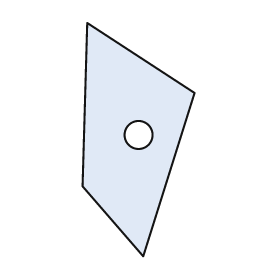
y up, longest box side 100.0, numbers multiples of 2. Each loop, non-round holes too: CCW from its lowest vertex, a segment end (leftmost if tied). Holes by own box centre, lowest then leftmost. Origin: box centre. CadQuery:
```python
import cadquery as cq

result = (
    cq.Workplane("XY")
    .moveTo(2.0, -50.0)
    .lineTo(24.0, 20.0)
    .lineTo(-22.0, 50.0)
    .lineTo(-24.0, -20.0)
    .close()
    .moveTo(0.0, 2.0)
    .circle(6.0)
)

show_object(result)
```